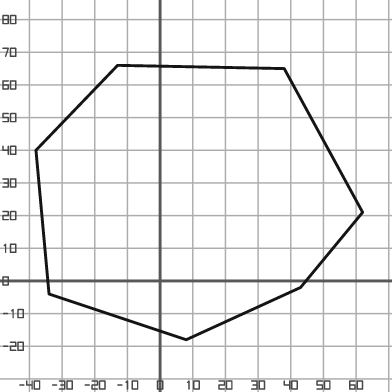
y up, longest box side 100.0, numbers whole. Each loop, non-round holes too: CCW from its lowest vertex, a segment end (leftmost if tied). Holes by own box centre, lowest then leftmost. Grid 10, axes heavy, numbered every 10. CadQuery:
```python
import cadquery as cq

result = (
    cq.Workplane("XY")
    .moveTo(8.0, -18.0)
    .lineTo(43.0, -2.0)
    .lineTo(62.0, 21.0)
    .lineTo(38.0, 65.0)
    .lineTo(-13.0, 66.0)
    .lineTo(-38.0, 40.0)
    .lineTo(-34.0, -4.0)
    .close()
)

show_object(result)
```